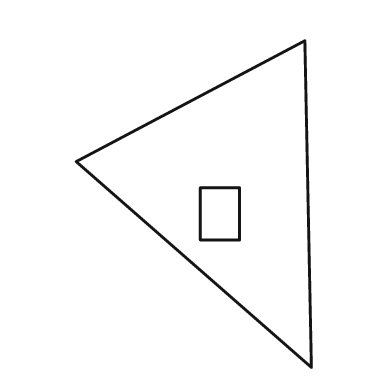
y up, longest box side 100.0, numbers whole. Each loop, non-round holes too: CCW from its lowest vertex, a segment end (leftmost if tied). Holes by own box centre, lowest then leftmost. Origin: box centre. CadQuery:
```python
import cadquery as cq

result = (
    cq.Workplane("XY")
    .moveTo(36.0, -50.0)
    .lineTo(34.0, 50.0)
    .lineTo(-36.0, 13.0)
    .close()
    .moveTo(2.0, -11.0)
    .lineTo(14.0, -11.0)
    .lineTo(14.0, 5.0)
    .lineTo(2.0, 5.0)
    .close()
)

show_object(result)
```